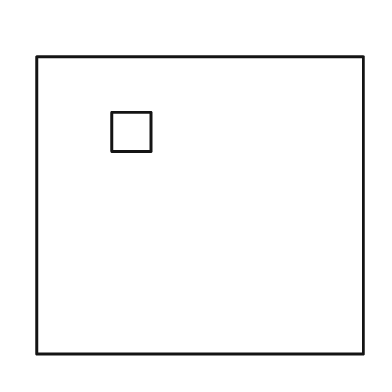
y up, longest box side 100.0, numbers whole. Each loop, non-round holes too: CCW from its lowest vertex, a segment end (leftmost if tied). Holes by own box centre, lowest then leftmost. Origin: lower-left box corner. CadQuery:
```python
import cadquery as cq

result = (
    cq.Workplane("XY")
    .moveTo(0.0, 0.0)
    .lineTo(100.0, 0.0)
    .lineTo(100.0, 91.0)
    .lineTo(0.0, 91.0)
    .close()
    .moveTo(23.0, 62.0)
    .lineTo(35.0, 62.0)
    .lineTo(35.0, 74.0)
    .lineTo(23.0, 74.0)
    .close()
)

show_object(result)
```